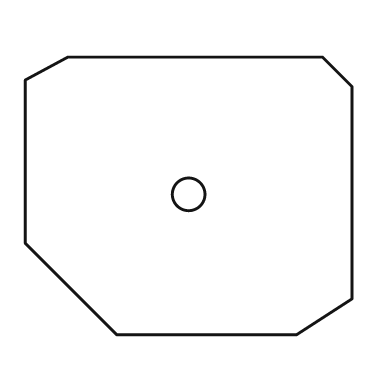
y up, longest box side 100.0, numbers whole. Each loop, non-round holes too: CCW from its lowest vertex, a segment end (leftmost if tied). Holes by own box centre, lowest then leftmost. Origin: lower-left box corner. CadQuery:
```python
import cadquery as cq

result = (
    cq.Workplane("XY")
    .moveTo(28.0, 0.0)
    .lineTo(83.0, 0.0)
    .lineTo(100.0, 11.0)
    .lineTo(100.0, 76.0)
    .lineTo(91.0, 85.0)
    .lineTo(13.0, 85.0)
    .lineTo(0.0, 78.0)
    .lineTo(0.0, 28.0)
    .close()
    .moveTo(50.0, 43.0)
    .circle(5.0)
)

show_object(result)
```